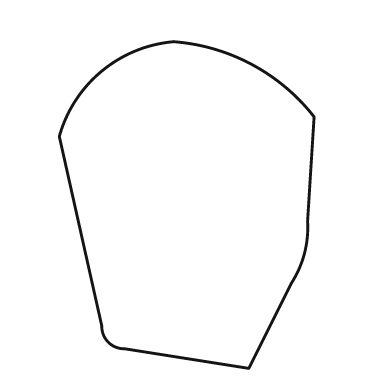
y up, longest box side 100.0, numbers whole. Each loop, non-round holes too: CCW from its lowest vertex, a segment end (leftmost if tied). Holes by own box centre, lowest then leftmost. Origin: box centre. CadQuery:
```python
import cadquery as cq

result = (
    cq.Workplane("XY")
    .moveTo(19.0, -50.0)
    .lineTo(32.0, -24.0)
    .threePointArc((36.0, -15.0), (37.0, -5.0))
    .lineTo(39.0, 27.0)
    .threePointArc((20.0, 43.0), (-4.0, 50.0))
    .threePointArc((-26.0, 41.0), (-39.0, 21.0))
    .lineTo(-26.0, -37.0)
    .threePointArc((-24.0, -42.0), (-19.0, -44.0))
    .close()
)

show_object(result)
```